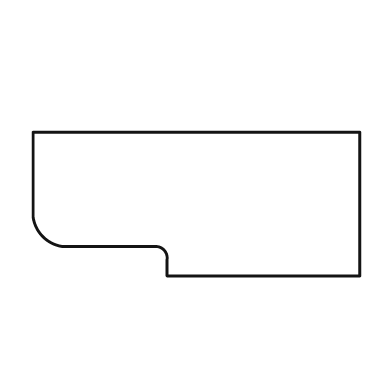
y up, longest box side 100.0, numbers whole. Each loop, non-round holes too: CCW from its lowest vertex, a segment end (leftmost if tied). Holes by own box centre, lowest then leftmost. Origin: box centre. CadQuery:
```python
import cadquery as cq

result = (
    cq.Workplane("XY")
    .moveTo(-9.0, -22.0)
    .lineTo(50.0, -22.0)
    .lineTo(50.0, 22.0)
    .lineTo(-50.0, 22.0)
    .lineTo(-50.0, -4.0)
    .threePointArc((-47.0, -10.0), (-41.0, -13.0))
    .lineTo(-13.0, -13.0)
    .threePointArc((-10.0, -14.0), (-9.0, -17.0))
    .close()
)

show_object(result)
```